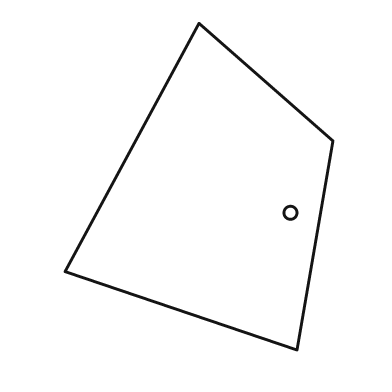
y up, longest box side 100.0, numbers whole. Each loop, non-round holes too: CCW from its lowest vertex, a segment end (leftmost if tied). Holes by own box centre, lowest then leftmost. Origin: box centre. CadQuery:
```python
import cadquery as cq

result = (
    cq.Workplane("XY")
    .moveTo(30.0, -50.0)
    .lineTo(41.0, 14.0)
    .lineTo(0.0, 50.0)
    .lineTo(-41.0, -26.0)
    .close()
    .moveTo(28.0, -8.0)
    .circle(2.0)
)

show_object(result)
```